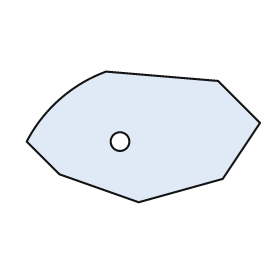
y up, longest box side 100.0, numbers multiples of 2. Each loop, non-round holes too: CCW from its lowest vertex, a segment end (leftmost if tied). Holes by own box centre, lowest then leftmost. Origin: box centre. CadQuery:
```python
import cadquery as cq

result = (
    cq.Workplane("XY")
    .moveTo(-2.0, -28.0)
    .lineTo(34.0, -18.0)
    .lineTo(50.0, 6.0)
    .lineTo(32.0, 24.0)
    .lineTo(-16.0, 28.0)
    .threePointArc((-36.0, 16.0), (-50.0, -2.0))
    .lineTo(-36.0, -16.0)
    .close()
    .moveTo(-10.0, -2.0)
    .circle(4.0)
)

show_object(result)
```